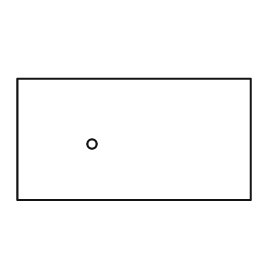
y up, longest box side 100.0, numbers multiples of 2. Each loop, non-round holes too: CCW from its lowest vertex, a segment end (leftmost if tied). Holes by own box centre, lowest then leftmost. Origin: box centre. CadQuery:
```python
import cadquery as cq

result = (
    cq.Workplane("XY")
    .moveTo(-50.0, -26.0)
    .lineTo(50.0, -26.0)
    .lineTo(50.0, 26.0)
    .lineTo(-50.0, 26.0)
    .close()
    .moveTo(-18.0, -2.0)
    .circle(2.0)
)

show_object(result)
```